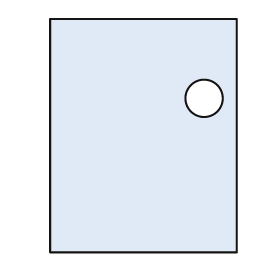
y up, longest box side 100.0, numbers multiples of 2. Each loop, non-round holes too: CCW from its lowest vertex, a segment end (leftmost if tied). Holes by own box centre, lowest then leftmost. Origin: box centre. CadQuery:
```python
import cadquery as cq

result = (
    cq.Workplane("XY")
    .moveTo(-40.0, -50.0)
    .lineTo(40.0, -50.0)
    .lineTo(40.0, 50.0)
    .lineTo(-40.0, 50.0)
    .close()
    .moveTo(26.0, 16.0)
    .circle(8.0)
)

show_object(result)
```